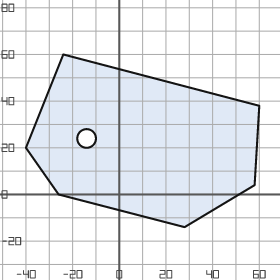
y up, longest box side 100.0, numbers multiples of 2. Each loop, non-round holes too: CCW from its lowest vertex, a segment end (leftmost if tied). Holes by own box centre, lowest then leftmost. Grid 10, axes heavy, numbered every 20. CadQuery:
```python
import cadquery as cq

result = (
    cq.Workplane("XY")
    .moveTo(28.0, -14.0)
    .lineTo(58.0, 4.0)
    .lineTo(60.0, 38.0)
    .lineTo(-24.0, 60.0)
    .lineTo(-40.0, 20.0)
    .lineTo(-26.0, 0.0)
    .close()
    .moveTo(-14.0, 24.0)
    .circle(4.0)
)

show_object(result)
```